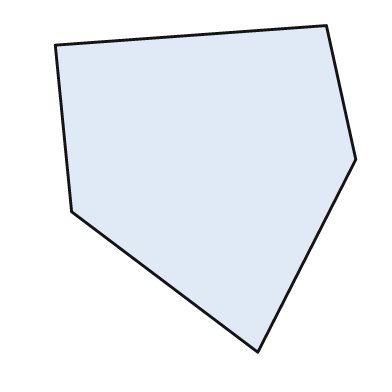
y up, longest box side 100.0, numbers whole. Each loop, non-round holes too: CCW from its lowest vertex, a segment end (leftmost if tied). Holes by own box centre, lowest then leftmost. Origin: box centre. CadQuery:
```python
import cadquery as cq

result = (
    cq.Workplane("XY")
    .moveTo(16.0, -50.0)
    .lineTo(46.0, 9.0)
    .lineTo(37.0, 50.0)
    .lineTo(-46.0, 44.0)
    .lineTo(-41.0, -7.0)
    .close()
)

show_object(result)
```